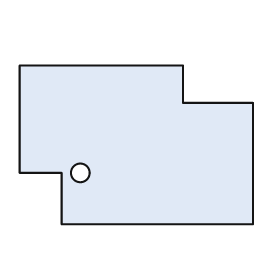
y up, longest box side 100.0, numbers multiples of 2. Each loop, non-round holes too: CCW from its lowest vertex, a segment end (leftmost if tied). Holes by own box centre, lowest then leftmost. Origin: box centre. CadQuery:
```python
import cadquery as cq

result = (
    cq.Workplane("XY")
    .moveTo(-32.0, -34.0)
    .lineTo(50.0, -34.0)
    .lineTo(50.0, 18.0)
    .lineTo(20.0, 18.0)
    .lineTo(20.0, 34.0)
    .lineTo(-50.0, 34.0)
    .lineTo(-50.0, -12.0)
    .lineTo(-32.0, -12.0)
    .close()
    .moveTo(-24.0, -12.0)
    .circle(4.0)
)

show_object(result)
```